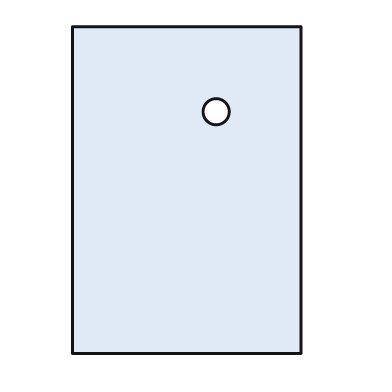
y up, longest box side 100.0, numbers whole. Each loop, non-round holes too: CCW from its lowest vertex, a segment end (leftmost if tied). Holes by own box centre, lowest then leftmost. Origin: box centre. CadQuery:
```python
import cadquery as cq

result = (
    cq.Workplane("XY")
    .moveTo(-35.0, -50.0)
    .lineTo(35.0, -50.0)
    .lineTo(35.0, 50.0)
    .lineTo(-35.0, 50.0)
    .close()
    .moveTo(9.0, 24.0)
    .circle(4.0)
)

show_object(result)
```